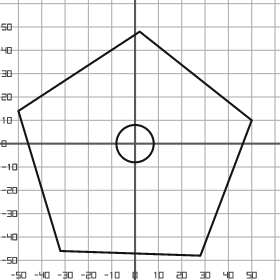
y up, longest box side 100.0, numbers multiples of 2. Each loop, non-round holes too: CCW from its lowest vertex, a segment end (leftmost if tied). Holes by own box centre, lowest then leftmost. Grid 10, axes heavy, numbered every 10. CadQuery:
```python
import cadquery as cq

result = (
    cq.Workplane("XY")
    .moveTo(28.0, -48.0)
    .lineTo(50.0, 10.0)
    .lineTo(2.0, 48.0)
    .lineTo(-50.0, 14.0)
    .lineTo(-32.0, -46.0)
    .close()
    .moveTo(0.0, 0.0)
    .circle(8.0)
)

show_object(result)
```